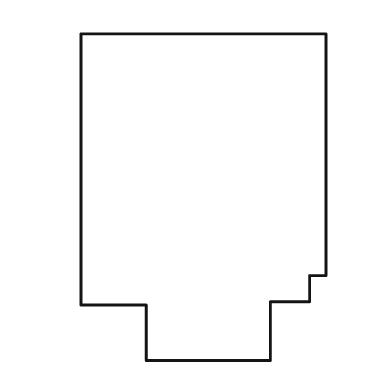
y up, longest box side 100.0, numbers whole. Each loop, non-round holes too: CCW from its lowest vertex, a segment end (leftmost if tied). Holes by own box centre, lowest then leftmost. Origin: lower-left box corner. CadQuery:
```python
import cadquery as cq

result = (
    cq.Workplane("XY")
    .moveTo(20.0, 0.0)
    .lineTo(58.0, 0.0)
    .lineTo(58.0, 18.0)
    .lineTo(70.0, 18.0)
    .lineTo(70.0, 26.0)
    .lineTo(75.0, 26.0)
    .lineTo(75.0, 100.0)
    .lineTo(0.0, 100.0)
    .lineTo(0.0, 17.0)
    .lineTo(20.0, 17.0)
    .close()
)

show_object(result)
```